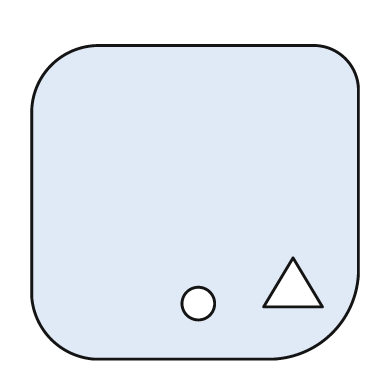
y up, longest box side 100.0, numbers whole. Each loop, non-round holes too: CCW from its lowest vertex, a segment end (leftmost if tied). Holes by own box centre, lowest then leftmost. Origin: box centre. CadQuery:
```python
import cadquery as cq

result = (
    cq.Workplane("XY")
    .moveTo(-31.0, -48.0)
    .lineTo(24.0, -48.0)
    .threePointArc((42.0, -40.0), (50.0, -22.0))
    .lineTo(50.0, 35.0)
    .threePointArc((46.0, 44.0), (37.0, 48.0))
    .lineTo(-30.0, 48.0)
    .threePointArc((-44.0, 42.0), (-50.0, 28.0))
    .lineTo(-50.0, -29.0)
    .threePointArc((-44.0, -42.0), (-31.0, -48.0))
    .close()
    .moveTo(1.0, -31.0)
    .circle(5.0)
    .moveTo(21.0, -32.0)
    .lineTo(39.0, -32.0)
    .lineTo(30.0, -17.0)
    .close()
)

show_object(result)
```